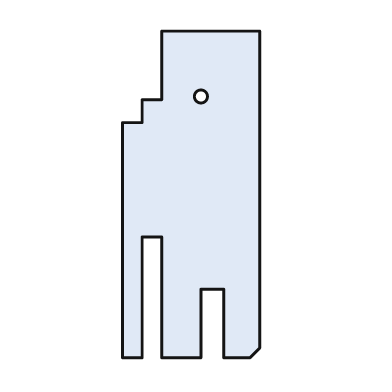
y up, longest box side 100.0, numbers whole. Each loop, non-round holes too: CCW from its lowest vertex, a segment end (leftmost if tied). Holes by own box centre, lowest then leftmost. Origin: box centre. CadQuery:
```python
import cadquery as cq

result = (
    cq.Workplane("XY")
    .moveTo(-21.0, -50.0)
    .lineTo(-15.0, -50.0)
    .lineTo(-15.0, -13.0)
    .lineTo(-9.0, -13.0)
    .lineTo(-9.0, -50.0)
    .lineTo(3.0, -50.0)
    .lineTo(3.0, -29.0)
    .lineTo(10.0, -29.0)
    .lineTo(10.0, -50.0)
    .lineTo(18.0, -50.0)
    .lineTo(21.0, -47.0)
    .lineTo(21.0, 50.0)
    .lineTo(-9.0, 50.0)
    .lineTo(-9.0, 29.0)
    .lineTo(-15.0, 29.0)
    .lineTo(-15.0, 22.0)
    .lineTo(-21.0, 22.0)
    .close()
    .moveTo(3.0, 30.0)
    .circle(2.0)
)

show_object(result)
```